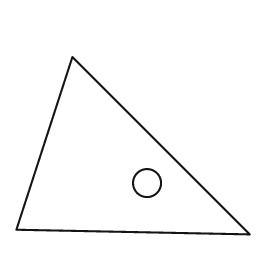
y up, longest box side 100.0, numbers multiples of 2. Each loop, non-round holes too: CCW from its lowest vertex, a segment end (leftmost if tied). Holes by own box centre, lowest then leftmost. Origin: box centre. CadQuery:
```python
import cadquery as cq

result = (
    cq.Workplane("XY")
    .moveTo(50.0, -38.0)
    .lineTo(-26.0, 38.0)
    .lineTo(-50.0, -36.0)
    .close()
    .moveTo(6.0, -16.0)
    .circle(6.0)
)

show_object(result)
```